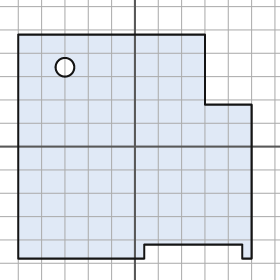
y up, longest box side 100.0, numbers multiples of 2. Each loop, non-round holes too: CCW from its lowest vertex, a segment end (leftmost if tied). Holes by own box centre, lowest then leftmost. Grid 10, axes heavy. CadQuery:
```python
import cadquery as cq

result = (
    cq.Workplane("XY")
    .moveTo(-50.0, -48.0)
    .lineTo(4.0, -48.0)
    .lineTo(4.0, -42.0)
    .lineTo(46.0, -42.0)
    .lineTo(46.0, -48.0)
    .lineTo(50.0, -48.0)
    .lineTo(50.0, 18.0)
    .lineTo(30.0, 18.0)
    .lineTo(30.0, 48.0)
    .lineTo(-50.0, 48.0)
    .close()
    .moveTo(-30.0, 34.0)
    .circle(4.0)
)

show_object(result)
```